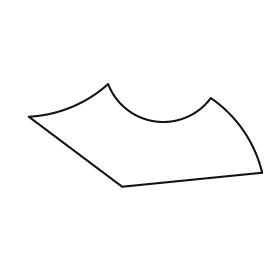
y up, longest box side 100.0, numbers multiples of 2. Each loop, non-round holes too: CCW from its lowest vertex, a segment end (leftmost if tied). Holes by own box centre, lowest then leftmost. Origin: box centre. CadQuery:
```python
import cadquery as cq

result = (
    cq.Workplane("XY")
    .moveTo(-10.0, -22.0)
    .lineTo(50.0, -16.0)
    .threePointArc((42.0, 2.0), (28.0, 16.0))
    .threePointArc((4.0, 6.0), (-16.0, 22.0))
    .threePointArc((-32.0, 12.0), (-50.0, 8.0))
    .close()
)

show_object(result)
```